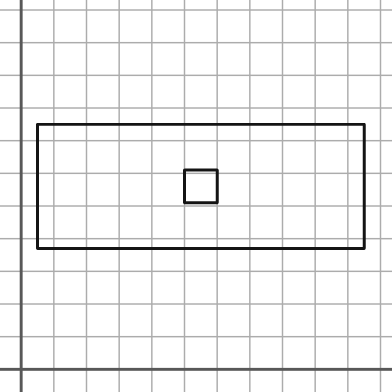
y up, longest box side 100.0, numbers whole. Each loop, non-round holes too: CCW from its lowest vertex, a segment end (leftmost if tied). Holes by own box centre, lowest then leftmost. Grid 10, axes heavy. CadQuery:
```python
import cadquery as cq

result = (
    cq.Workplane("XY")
    .moveTo(5.0, 37.0)
    .lineTo(105.0, 37.0)
    .lineTo(105.0, 75.0)
    .lineTo(5.0, 75.0)
    .close()
    .moveTo(50.0, 51.0)
    .lineTo(60.0, 51.0)
    .lineTo(60.0, 61.0)
    .lineTo(50.0, 61.0)
    .close()
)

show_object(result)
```